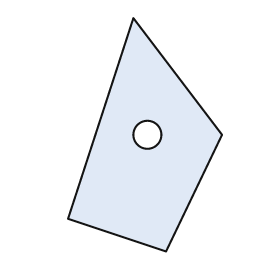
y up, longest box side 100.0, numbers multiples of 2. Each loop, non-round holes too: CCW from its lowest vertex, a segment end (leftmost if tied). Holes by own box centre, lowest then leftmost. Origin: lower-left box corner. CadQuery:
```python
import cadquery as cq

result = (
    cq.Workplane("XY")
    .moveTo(42.0, 0.0)
    .lineTo(66.0, 50.0)
    .lineTo(28.0, 100.0)
    .lineTo(0.0, 14.0)
    .close()
    .moveTo(34.0, 50.0)
    .circle(6.0)
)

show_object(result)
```